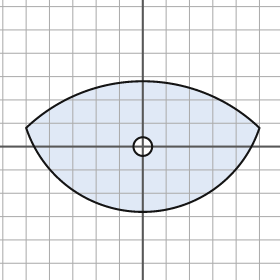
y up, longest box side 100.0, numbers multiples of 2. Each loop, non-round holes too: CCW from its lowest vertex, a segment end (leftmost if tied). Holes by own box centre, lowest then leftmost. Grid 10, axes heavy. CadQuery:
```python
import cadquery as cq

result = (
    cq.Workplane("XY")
    .moveTo(-50.0, 8.0)
    .threePointArc((0.0, -28.0), (50.0, 8.0))
    .threePointArc((0.0, 28.0), (-50.0, 8.0))
    .close()
    .moveTo(0.0, 0.0)
    .circle(4.0)
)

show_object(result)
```